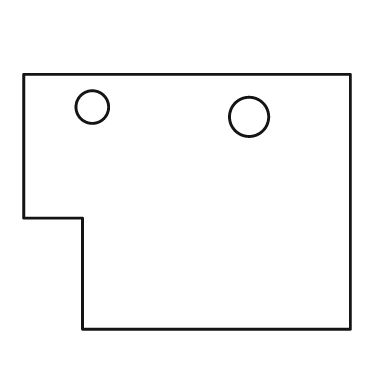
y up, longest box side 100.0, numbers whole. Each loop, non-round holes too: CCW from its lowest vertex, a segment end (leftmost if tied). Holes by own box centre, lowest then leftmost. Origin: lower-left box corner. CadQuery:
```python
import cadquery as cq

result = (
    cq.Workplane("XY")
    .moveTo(18.0, 0.0)
    .lineTo(100.0, 0.0)
    .lineTo(100.0, 78.0)
    .lineTo(0.0, 78.0)
    .lineTo(0.0, 34.0)
    .lineTo(18.0, 34.0)
    .close()
    .moveTo(69.0, 65.0)
    .circle(6.0)
    .moveTo(21.0, 68.0)
    .circle(5.0)
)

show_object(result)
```